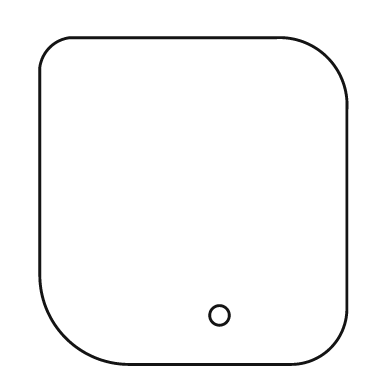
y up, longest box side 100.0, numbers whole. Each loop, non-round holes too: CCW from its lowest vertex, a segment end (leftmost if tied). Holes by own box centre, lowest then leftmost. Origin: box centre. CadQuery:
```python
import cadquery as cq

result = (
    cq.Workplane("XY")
    .moveTo(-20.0, -50.0)
    .lineTo(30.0, -50.0)
    .threePointArc((42.0, -45.0), (47.0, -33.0))
    .lineTo(47.0, 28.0)
    .threePointArc((41.0, 44.0), (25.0, 50.0))
    .lineTo(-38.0, 50.0)
    .threePointArc((-44.0, 47.0), (-47.0, 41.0))
    .lineTo(-47.0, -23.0)
    .threePointArc((-39.0, -42.0), (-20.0, -50.0))
    .close()
    .moveTo(8.0, -35.0)
    .circle(3.0)
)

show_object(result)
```